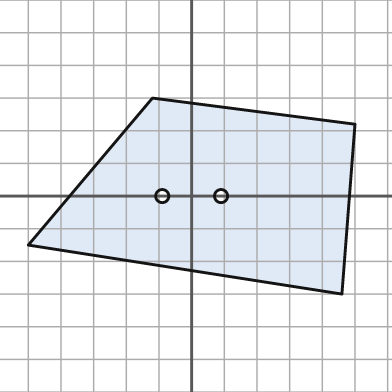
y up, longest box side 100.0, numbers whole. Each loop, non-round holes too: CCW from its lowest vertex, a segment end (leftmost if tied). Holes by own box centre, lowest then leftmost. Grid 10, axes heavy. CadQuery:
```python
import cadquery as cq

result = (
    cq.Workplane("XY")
    .moveTo(46.0, -30.0)
    .lineTo(50.0, 22.0)
    .lineTo(-12.0, 30.0)
    .lineTo(-50.0, -15.0)
    .close()
    .moveTo(-9.0, 0.0)
    .circle(2.0)
    .moveTo(9.0, 0.0)
    .circle(2.0)
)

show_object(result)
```